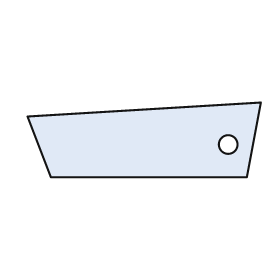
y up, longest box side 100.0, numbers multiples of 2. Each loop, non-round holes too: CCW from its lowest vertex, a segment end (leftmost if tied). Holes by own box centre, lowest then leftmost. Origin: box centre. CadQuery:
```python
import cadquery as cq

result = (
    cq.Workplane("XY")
    .moveTo(-40.0, -16.0)
    .lineTo(44.0, -16.0)
    .lineTo(50.0, 16.0)
    .lineTo(-50.0, 10.0)
    .close()
    .moveTo(36.0, -2.0)
    .circle(4.0)
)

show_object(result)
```